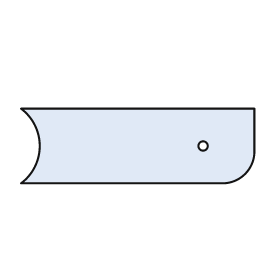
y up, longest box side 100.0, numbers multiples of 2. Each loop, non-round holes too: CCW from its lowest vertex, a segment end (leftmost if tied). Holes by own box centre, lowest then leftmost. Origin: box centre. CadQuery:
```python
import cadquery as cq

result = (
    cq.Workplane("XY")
    .moveTo(-50.0, -16.0)
    .lineTo(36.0, -16.0)
    .threePointArc((46.0, -12.0), (50.0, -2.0))
    .lineTo(50.0, 16.0)
    .lineTo(-50.0, 16.0)
    .threePointArc((-42.0, 0.0), (-50.0, -16.0))
    .close()
    .moveTo(28.0, 0.0)
    .circle(2.0)
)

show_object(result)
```